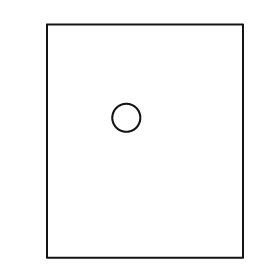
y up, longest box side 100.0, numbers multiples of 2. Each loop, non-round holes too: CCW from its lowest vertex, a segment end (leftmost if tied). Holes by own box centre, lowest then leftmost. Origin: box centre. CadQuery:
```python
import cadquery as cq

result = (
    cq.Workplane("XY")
    .moveTo(-42.0, -50.0)
    .lineTo(42.0, -50.0)
    .lineTo(42.0, 50.0)
    .lineTo(-42.0, 50.0)
    .close()
    .moveTo(-8.0, 10.0)
    .circle(6.0)
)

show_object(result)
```